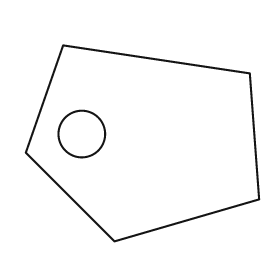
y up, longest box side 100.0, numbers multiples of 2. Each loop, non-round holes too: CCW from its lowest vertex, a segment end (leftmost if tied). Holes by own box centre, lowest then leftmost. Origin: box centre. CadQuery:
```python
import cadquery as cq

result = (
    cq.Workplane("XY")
    .moveTo(-12.0, -42.0)
    .lineTo(50.0, -24.0)
    .lineTo(46.0, 30.0)
    .lineTo(-34.0, 42.0)
    .lineTo(-50.0, -4.0)
    .close()
    .moveTo(-26.0, 4.0)
    .circle(10.0)
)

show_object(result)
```